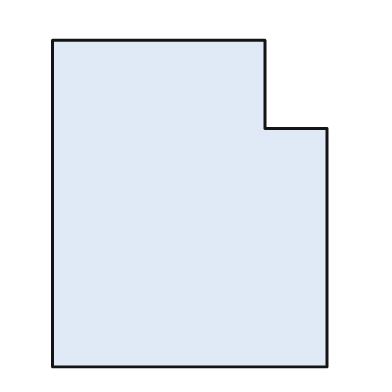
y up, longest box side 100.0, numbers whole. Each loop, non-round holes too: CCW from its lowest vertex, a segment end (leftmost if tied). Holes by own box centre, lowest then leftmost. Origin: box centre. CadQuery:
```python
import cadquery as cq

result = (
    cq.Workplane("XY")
    .moveTo(-42.0, -50.0)
    .lineTo(42.0, -50.0)
    .lineTo(42.0, 23.0)
    .lineTo(23.0, 23.0)
    .lineTo(23.0, 50.0)
    .lineTo(-42.0, 50.0)
    .close()
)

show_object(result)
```